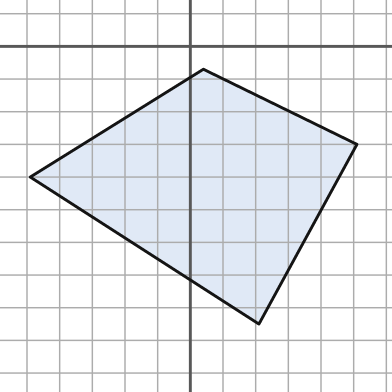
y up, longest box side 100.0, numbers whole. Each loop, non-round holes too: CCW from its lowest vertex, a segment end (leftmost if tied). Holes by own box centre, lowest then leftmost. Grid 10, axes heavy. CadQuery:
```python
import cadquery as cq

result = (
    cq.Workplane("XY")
    .moveTo(21.0, -85.0)
    .lineTo(51.0, -30.0)
    .lineTo(4.0, -7.0)
    .lineTo(-49.0, -40.0)
    .close()
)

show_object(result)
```